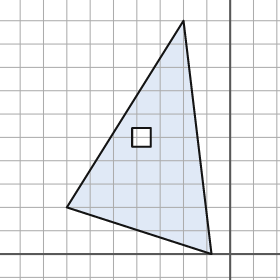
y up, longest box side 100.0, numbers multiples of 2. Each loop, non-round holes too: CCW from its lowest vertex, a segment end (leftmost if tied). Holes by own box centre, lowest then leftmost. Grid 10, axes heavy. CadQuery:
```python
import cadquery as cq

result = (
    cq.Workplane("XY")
    .moveTo(-8.0, 0.0)
    .lineTo(-20.0, 100.0)
    .lineTo(-70.0, 20.0)
    .close()
    .moveTo(-42.0, 46.0)
    .lineTo(-34.0, 46.0)
    .lineTo(-34.0, 54.0)
    .lineTo(-42.0, 54.0)
    .close()
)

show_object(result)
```